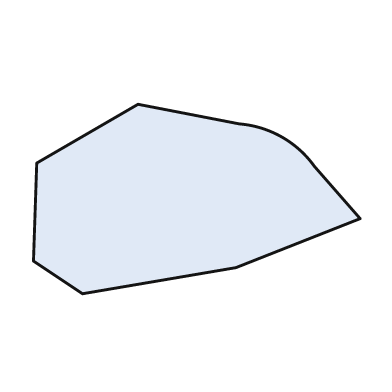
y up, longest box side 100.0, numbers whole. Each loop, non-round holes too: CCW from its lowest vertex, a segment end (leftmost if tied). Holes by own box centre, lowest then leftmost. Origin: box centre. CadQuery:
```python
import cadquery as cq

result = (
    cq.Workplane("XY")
    .moveTo(-35.0, -29.0)
    .lineTo(12.0, -21.0)
    .lineTo(50.0, -6.0)
    .lineTo(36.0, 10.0)
    .threePointArc((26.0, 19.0), (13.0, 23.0))
    .lineTo(-18.0, 29.0)
    .lineTo(-49.0, 11.0)
    .lineTo(-50.0, -19.0)
    .close()
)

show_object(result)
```